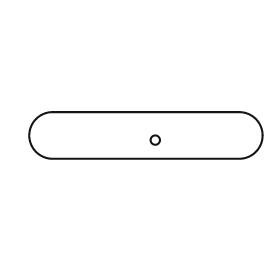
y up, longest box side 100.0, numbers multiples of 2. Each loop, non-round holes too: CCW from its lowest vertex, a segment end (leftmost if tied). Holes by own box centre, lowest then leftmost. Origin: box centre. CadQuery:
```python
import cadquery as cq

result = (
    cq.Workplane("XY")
    .moveTo(-40.0, -10.0)
    .lineTo(40.0, -10.0)
    .threePointArc((50.0, 0.0), (40.0, 10.0))
    .lineTo(-40.0, 10.0)
    .threePointArc((-50.0, 0.0), (-40.0, -10.0))
    .close()
    .moveTo(4.0, -2.0)
    .circle(2.0)
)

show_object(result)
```